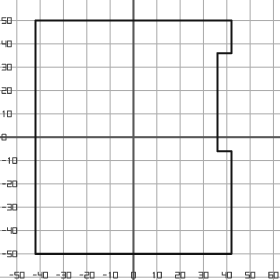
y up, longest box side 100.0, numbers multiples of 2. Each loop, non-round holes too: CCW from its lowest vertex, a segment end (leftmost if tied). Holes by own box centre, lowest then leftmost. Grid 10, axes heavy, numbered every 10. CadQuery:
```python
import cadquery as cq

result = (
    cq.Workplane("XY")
    .moveTo(-42.0, -50.0)
    .lineTo(42.0, -50.0)
    .lineTo(42.0, -6.0)
    .lineTo(36.0, -6.0)
    .lineTo(36.0, 36.0)
    .lineTo(42.0, 36.0)
    .lineTo(42.0, 50.0)
    .lineTo(-42.0, 50.0)
    .close()
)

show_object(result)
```